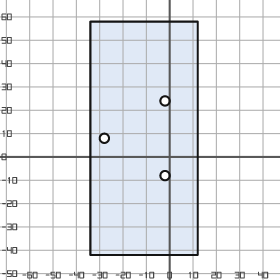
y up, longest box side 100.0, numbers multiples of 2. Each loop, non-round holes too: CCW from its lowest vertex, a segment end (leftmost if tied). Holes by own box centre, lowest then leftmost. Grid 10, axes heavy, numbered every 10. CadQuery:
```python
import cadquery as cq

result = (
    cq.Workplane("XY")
    .moveTo(-34.0, -42.0)
    .lineTo(12.0, -42.0)
    .lineTo(12.0, 58.0)
    .lineTo(-34.0, 58.0)
    .close()
    .moveTo(-2.0, -8.0)
    .circle(2.0)
    .moveTo(-28.0, 8.0)
    .circle(2.0)
    .moveTo(-2.0, 24.0)
    .circle(2.0)
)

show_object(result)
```